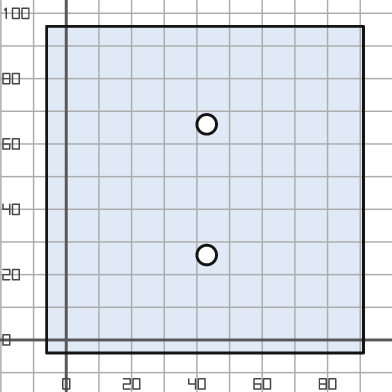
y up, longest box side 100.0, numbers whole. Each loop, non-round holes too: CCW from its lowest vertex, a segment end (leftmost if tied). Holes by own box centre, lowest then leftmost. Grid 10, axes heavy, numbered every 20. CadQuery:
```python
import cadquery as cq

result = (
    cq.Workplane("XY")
    .moveTo(-6.0, -4.0)
    .lineTo(91.0, -4.0)
    .lineTo(91.0, 96.0)
    .lineTo(-6.0, 96.0)
    .close()
    .moveTo(43.0, 26.0)
    .circle(3.0)
    .moveTo(43.0, 66.0)
    .circle(3.0)
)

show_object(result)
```